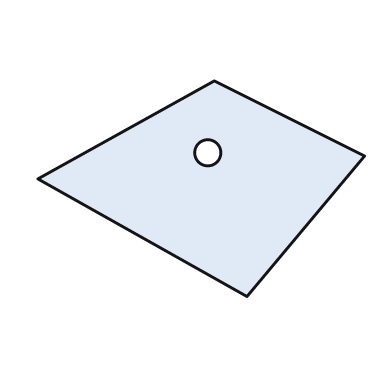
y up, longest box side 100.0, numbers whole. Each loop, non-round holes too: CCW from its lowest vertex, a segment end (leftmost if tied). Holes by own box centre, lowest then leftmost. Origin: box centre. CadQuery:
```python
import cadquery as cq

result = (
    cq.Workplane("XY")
    .moveTo(14.0, -33.0)
    .lineTo(50.0, 10.0)
    .lineTo(4.0, 33.0)
    .lineTo(-50.0, 3.0)
    .close()
    .moveTo(2.0, 11.0)
    .circle(4.0)
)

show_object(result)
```